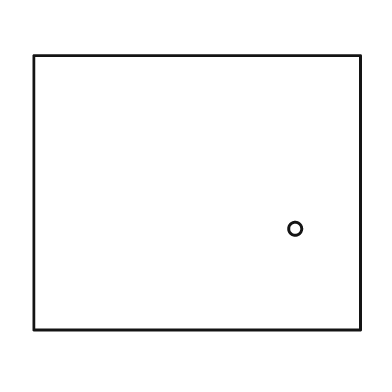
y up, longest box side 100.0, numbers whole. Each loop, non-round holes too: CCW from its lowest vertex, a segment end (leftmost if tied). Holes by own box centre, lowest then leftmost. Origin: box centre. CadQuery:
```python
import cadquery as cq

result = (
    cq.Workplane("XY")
    .moveTo(-50.0, -42.0)
    .lineTo(50.0, -42.0)
    .lineTo(50.0, 42.0)
    .lineTo(-50.0, 42.0)
    .close()
    .moveTo(30.0, -11.0)
    .circle(2.0)
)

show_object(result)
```